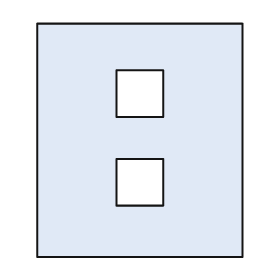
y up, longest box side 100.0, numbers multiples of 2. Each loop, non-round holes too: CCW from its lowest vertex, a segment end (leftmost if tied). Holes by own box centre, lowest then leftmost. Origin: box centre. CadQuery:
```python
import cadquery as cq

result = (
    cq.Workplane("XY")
    .moveTo(-44.0, -50.0)
    .lineTo(44.0, -50.0)
    .lineTo(44.0, 50.0)
    .lineTo(-44.0, 50.0)
    .close()
    .moveTo(-10.0, -28.0)
    .lineTo(10.0, -28.0)
    .lineTo(10.0, -8.0)
    .lineTo(-10.0, -8.0)
    .close()
    .moveTo(-10.0, 10.0)
    .lineTo(10.0, 10.0)
    .lineTo(10.0, 30.0)
    .lineTo(-10.0, 30.0)
    .close()
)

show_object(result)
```